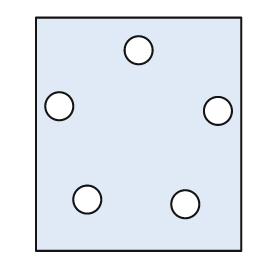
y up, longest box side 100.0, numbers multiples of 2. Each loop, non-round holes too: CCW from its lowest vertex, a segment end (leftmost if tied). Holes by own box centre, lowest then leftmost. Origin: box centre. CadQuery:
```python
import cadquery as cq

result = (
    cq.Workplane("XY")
    .moveTo(-44.0, -50.0)
    .lineTo(44.0, -50.0)
    .lineTo(44.0, 50.0)
    .lineTo(-44.0, 50.0)
    .close()
    .moveTo(20.0, -30.0)
    .circle(6.0)
    .moveTo(-22.0, -28.0)
    .circle(6.0)
    .moveTo(34.0, 10.0)
    .circle(6.0)
    .moveTo(-34.0, 12.0)
    .circle(6.0)
    .moveTo(0.0, 36.0)
    .circle(6.0)
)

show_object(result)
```